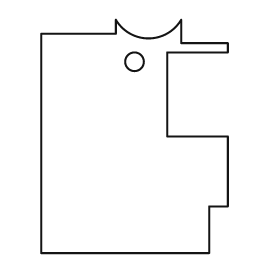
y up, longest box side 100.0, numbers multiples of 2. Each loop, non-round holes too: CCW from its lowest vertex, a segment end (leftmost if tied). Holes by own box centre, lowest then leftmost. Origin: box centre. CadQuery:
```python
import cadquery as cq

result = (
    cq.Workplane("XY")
    .moveTo(-40.0, -50.0)
    .lineTo(32.0, -50.0)
    .lineTo(32.0, -30.0)
    .lineTo(40.0, -30.0)
    .lineTo(40.0, 0.0)
    .lineTo(14.0, 0.0)
    .lineTo(14.0, 36.0)
    .lineTo(40.0, 36.0)
    .lineTo(40.0, 40.0)
    .lineTo(20.0, 40.0)
    .lineTo(20.0, 50.0)
    .threePointArc((6.0, 42.0), (-8.0, 50.0))
    .lineTo(-8.0, 44.0)
    .lineTo(-40.0, 44.0)
    .close()
    .moveTo(0.0, 32.0)
    .circle(4.0)
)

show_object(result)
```